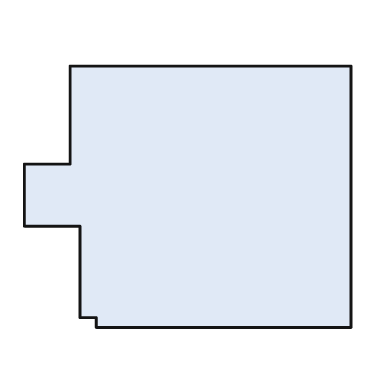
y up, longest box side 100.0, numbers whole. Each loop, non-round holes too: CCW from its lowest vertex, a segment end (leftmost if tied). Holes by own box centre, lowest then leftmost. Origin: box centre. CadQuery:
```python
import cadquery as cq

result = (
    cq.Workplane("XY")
    .moveTo(-28.0, -40.0)
    .lineTo(50.0, -40.0)
    .lineTo(50.0, 40.0)
    .lineTo(-36.0, 40.0)
    .lineTo(-36.0, 10.0)
    .lineTo(-50.0, 10.0)
    .lineTo(-50.0, -9.0)
    .lineTo(-33.0, -9.0)
    .lineTo(-33.0, -37.0)
    .lineTo(-28.0, -37.0)
    .close()
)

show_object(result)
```